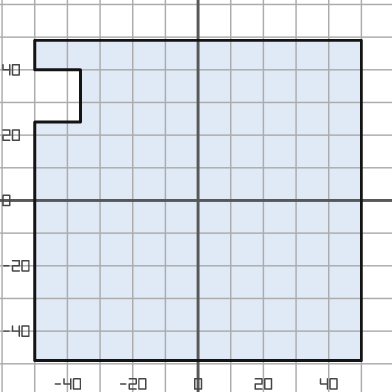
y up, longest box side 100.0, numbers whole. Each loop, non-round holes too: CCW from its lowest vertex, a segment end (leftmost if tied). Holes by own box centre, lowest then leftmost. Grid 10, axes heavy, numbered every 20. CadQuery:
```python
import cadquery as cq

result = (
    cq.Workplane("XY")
    .moveTo(-50.0, -49.0)
    .lineTo(50.0, -49.0)
    .lineTo(50.0, 49.0)
    .lineTo(-50.0, 49.0)
    .lineTo(-50.0, 40.0)
    .lineTo(-36.0, 40.0)
    .lineTo(-36.0, 24.0)
    .lineTo(-50.0, 24.0)
    .close()
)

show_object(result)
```